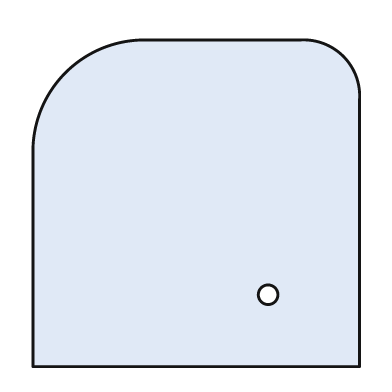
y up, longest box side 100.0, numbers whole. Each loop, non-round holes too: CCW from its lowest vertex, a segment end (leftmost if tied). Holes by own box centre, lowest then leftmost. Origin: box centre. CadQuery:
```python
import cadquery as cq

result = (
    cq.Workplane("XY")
    .moveTo(-50.0, -50.0)
    .lineTo(50.0, -50.0)
    .lineTo(50.0, 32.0)
    .threePointArc((45.0, 45.0), (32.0, 50.0))
    .lineTo(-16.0, 50.0)
    .threePointArc((-40.0, 40.0), (-50.0, 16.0))
    .close()
    .moveTo(22.0, -28.0)
    .circle(3.0)
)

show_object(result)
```